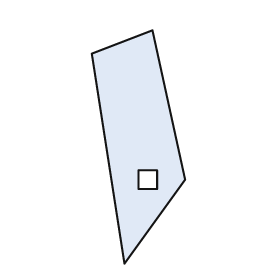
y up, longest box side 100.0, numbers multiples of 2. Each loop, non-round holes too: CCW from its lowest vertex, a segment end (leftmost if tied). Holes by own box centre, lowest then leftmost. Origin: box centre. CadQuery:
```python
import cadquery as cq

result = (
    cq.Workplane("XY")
    .moveTo(-6.0, -50.0)
    .lineTo(20.0, -14.0)
    .lineTo(6.0, 50.0)
    .lineTo(-20.0, 40.0)
    .close()
    .moveTo(0.0, -18.0)
    .lineTo(8.0, -18.0)
    .lineTo(8.0, -10.0)
    .lineTo(0.0, -10.0)
    .close()
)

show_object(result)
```